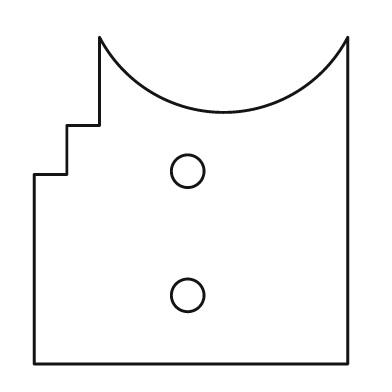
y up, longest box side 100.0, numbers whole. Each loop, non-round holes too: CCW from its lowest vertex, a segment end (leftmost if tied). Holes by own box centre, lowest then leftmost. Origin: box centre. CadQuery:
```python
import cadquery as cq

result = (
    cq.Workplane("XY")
    .moveTo(-48.0, -50.0)
    .lineTo(48.0, -50.0)
    .lineTo(48.0, 50.0)
    .threePointArc((10.0, 27.0), (-28.0, 50.0))
    .lineTo(-28.0, 23.0)
    .lineTo(-38.0, 23.0)
    .lineTo(-38.0, 8.0)
    .lineTo(-48.0, 8.0)
    .close()
    .moveTo(-1.0, -29.0)
    .circle(5.0)
    .moveTo(-1.0, 9.0)
    .circle(5.0)
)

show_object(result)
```